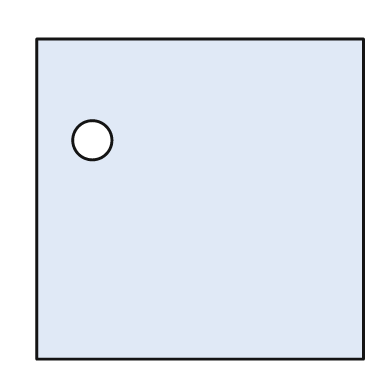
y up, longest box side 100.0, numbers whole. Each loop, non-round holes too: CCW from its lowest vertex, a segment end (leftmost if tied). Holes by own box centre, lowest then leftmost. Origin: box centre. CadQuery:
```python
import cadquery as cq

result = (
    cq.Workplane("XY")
    .moveTo(-50.0, -49.0)
    .lineTo(50.0, -49.0)
    .lineTo(50.0, 49.0)
    .lineTo(-50.0, 49.0)
    .close()
    .moveTo(-33.0, 18.0)
    .circle(6.0)
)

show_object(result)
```